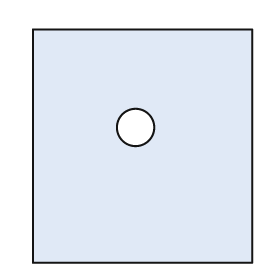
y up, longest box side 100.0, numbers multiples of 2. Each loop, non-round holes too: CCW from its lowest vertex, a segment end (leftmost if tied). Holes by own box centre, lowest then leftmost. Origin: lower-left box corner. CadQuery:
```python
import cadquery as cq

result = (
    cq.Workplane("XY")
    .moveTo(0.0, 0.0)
    .lineTo(94.0, 0.0)
    .lineTo(94.0, 100.0)
    .lineTo(0.0, 100.0)
    .close()
    .moveTo(44.0, 58.0)
    .circle(8.0)
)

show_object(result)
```